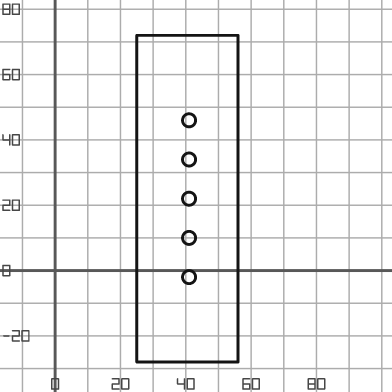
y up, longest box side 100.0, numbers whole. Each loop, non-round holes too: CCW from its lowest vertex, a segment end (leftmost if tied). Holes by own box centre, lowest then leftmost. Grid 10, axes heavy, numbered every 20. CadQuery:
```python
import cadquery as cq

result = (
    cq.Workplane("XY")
    .moveTo(25.0, -28.0)
    .lineTo(56.0, -28.0)
    .lineTo(56.0, 72.0)
    .lineTo(25.0, 72.0)
    .close()
    .moveTo(41.0, -2.0)
    .circle(2.0)
    .moveTo(41.0, 10.0)
    .circle(2.0)
    .moveTo(41.0, 22.0)
    .circle(2.0)
    .moveTo(41.0, 34.0)
    .circle(2.0)
    .moveTo(41.0, 46.0)
    .circle(2.0)
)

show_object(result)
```